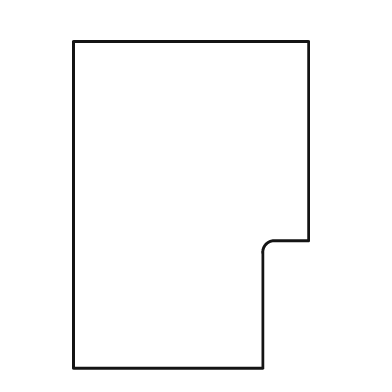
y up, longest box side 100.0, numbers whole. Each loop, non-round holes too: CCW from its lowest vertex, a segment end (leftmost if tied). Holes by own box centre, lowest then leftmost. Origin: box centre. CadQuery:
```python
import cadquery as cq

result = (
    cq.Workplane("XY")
    .moveTo(-36.0, -50.0)
    .lineTo(22.0, -50.0)
    .lineTo(22.0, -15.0)
    .threePointArc((23.0, -12.0), (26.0, -11.0))
    .lineTo(36.0, -11.0)
    .lineTo(36.0, 50.0)
    .lineTo(-36.0, 50.0)
    .close()
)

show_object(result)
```